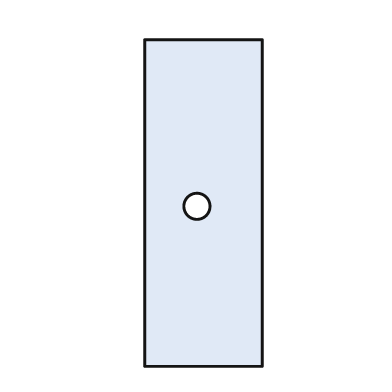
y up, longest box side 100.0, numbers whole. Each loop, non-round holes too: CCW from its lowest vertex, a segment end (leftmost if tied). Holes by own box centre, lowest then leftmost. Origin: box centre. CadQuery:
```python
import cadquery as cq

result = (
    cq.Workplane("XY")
    .moveTo(-18.0, -50.0)
    .lineTo(18.0, -50.0)
    .lineTo(18.0, 50.0)
    .lineTo(-18.0, 50.0)
    .close()
    .moveTo(-2.0, -1.0)
    .circle(4.0)
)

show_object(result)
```